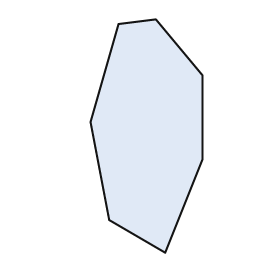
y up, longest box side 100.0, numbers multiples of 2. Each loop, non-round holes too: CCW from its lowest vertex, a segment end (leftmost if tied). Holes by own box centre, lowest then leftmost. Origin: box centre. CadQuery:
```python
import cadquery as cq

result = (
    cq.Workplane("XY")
    .moveTo(8.0, -50.0)
    .lineTo(24.0, -10.0)
    .lineTo(24.0, 26.0)
    .lineTo(4.0, 50.0)
    .lineTo(-12.0, 48.0)
    .lineTo(-24.0, 6.0)
    .lineTo(-16.0, -36.0)
    .close()
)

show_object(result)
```